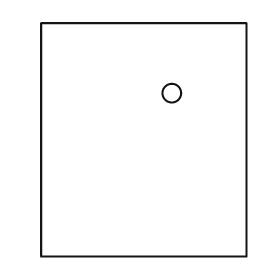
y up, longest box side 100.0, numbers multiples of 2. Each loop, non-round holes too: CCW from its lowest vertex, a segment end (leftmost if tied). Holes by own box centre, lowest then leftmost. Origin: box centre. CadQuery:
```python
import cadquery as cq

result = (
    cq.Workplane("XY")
    .moveTo(-44.0, -50.0)
    .lineTo(44.0, -50.0)
    .lineTo(44.0, 50.0)
    .lineTo(-44.0, 50.0)
    .close()
    .moveTo(12.0, 20.0)
    .circle(4.0)
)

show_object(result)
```